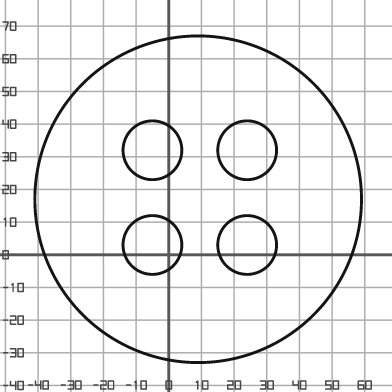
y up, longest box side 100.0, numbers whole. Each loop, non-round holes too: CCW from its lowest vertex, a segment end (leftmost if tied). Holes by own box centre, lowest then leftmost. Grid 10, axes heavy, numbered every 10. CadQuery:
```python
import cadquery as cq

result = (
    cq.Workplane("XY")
    .moveTo(9.0, 17.0)
    .circle(50.0)
    .moveTo(-5.0, 3.0)
    .circle(9.0)
    .moveTo(24.0, 3.0)
    .circle(9.0)
    .moveTo(-5.0, 32.0)
    .circle(9.0)
    .moveTo(24.0, 32.0)
    .circle(9.0)
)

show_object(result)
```